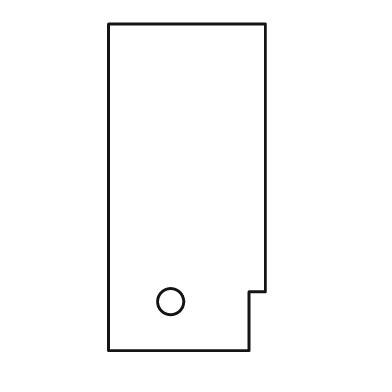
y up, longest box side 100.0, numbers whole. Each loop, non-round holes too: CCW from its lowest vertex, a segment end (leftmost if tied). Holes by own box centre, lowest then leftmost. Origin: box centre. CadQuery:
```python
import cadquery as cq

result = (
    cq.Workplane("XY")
    .moveTo(-24.0, -50.0)
    .lineTo(19.0, -50.0)
    .lineTo(19.0, -32.0)
    .lineTo(24.0, -32.0)
    .lineTo(24.0, 50.0)
    .lineTo(-24.0, 50.0)
    .close()
    .moveTo(-5.0, -35.0)
    .circle(4.0)
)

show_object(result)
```